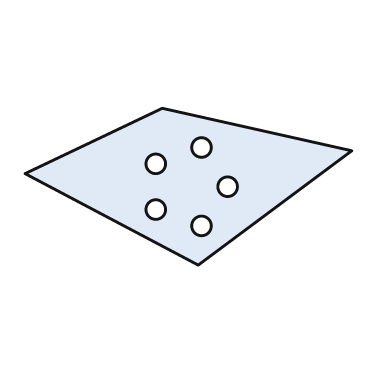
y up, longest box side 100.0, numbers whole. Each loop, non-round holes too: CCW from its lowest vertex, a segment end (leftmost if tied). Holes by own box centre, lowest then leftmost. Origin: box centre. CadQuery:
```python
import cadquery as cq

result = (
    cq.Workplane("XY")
    .moveTo(3.0, -24.0)
    .lineTo(50.0, 11.0)
    .lineTo(-8.0, 24.0)
    .lineTo(-50.0, 4.0)
    .close()
    .moveTo(4.0, -12.0)
    .circle(3.0)
    .moveTo(-10.0, -7.0)
    .circle(3.0)
    .moveTo(12.0, 0.0)
    .circle(3.0)
    .moveTo(-10.0, 7.0)
    .circle(3.0)
    .moveTo(4.0, 12.0)
    .circle(3.0)
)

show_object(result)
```